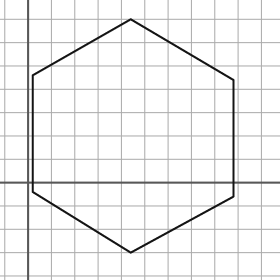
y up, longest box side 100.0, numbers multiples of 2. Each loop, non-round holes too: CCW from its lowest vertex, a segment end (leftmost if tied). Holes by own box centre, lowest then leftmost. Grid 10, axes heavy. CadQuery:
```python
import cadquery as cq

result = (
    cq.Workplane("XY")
    .moveTo(44.0, -30.0)
    .lineTo(88.0, -6.0)
    .lineTo(88.0, 44.0)
    .lineTo(44.0, 70.0)
    .lineTo(2.0, 46.0)
    .lineTo(2.0, -4.0)
    .close()
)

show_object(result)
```